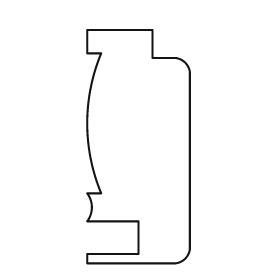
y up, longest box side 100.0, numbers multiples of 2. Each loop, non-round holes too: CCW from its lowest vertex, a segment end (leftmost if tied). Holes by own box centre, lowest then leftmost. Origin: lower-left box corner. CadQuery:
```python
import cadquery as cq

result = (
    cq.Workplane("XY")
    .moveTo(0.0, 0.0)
    .lineTo(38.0, 0.0)
    .threePointArc((42.0, 2.0), (44.0, 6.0))
    .lineTo(44.0, 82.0)
    .threePointArc((42.0, 86.0), (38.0, 88.0))
    .lineTo(28.0, 88.0)
    .lineTo(28.0, 100.0)
    .lineTo(0.0, 100.0)
    .lineTo(0.0, 90.0)
    .lineTo(6.0, 90.0)
    .threePointArc((0.0, 60.0), (6.0, 30.0))
    .lineTo(0.0, 30.0)
    .threePointArc((2.0, 24.0), (0.0, 18.0))
    .lineTo(22.0, 18.0)
    .lineTo(22.0, 4.0)
    .lineTo(0.0, 4.0)
    .close()
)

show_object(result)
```